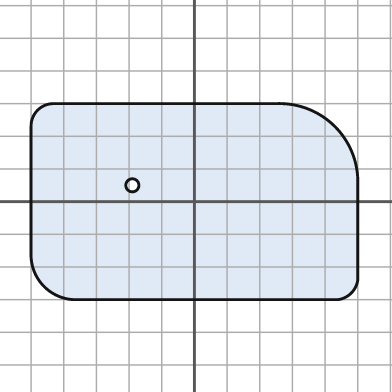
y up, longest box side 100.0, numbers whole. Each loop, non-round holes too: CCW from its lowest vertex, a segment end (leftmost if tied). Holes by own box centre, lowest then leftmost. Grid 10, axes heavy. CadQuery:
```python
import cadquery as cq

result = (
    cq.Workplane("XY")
    .moveTo(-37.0, -30.0)
    .lineTo(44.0, -30.0)
    .threePointArc((48.0, -28.0), (50.0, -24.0))
    .lineTo(50.0, 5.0)
    .threePointArc((43.0, 23.0), (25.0, 30.0))
    .lineTo(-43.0, 30.0)
    .threePointArc((-48.0, 28.0), (-50.0, 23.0))
    .lineTo(-50.0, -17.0)
    .threePointArc((-46.0, -26.0), (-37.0, -30.0))
    .close()
    .moveTo(-19.0, 5.0)
    .circle(2.0)
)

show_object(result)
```